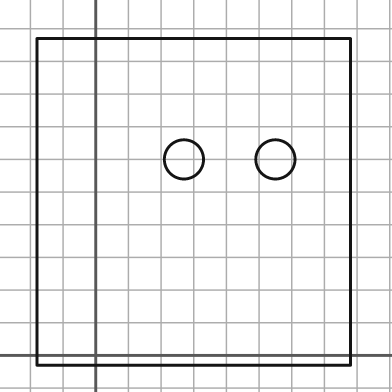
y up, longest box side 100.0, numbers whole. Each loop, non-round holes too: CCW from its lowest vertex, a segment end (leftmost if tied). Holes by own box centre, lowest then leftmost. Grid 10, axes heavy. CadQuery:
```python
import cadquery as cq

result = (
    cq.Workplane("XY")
    .moveTo(-18.0, -3.0)
    .lineTo(78.0, -3.0)
    .lineTo(78.0, 97.0)
    .lineTo(-18.0, 97.0)
    .close()
    .moveTo(27.0, 60.0)
    .circle(6.0)
    .moveTo(55.0, 60.0)
    .circle(6.0)
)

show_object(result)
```